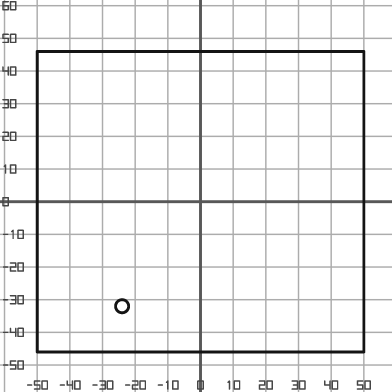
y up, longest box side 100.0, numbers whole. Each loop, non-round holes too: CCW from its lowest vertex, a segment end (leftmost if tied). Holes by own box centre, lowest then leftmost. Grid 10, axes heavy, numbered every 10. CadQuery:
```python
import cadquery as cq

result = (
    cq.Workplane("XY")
    .moveTo(-50.0, -46.0)
    .lineTo(50.0, -46.0)
    .lineTo(50.0, 46.0)
    .lineTo(-50.0, 46.0)
    .close()
    .moveTo(-24.0, -32.0)
    .circle(2.0)
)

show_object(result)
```